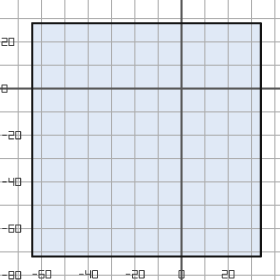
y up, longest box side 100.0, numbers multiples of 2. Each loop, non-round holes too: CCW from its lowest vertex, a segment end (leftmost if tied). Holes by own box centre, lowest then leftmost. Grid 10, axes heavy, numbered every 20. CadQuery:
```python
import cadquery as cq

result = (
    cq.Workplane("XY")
    .moveTo(-64.0, -72.0)
    .lineTo(34.0, -72.0)
    .lineTo(34.0, 28.0)
    .lineTo(-64.0, 28.0)
    .close()
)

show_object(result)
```